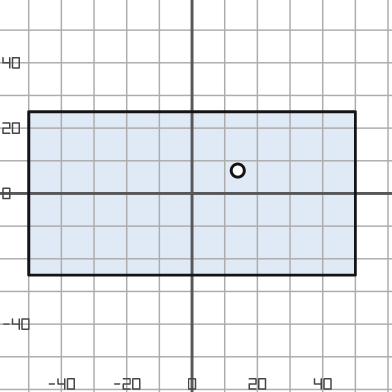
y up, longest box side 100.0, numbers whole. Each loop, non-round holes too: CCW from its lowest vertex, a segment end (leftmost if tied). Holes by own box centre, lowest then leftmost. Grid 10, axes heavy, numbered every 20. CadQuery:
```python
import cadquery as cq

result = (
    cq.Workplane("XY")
    .moveTo(-50.0, -25.0)
    .lineTo(50.0, -25.0)
    .lineTo(50.0, 25.0)
    .lineTo(-50.0, 25.0)
    .close()
    .moveTo(14.0, 7.0)
    .circle(2.0)
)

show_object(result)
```